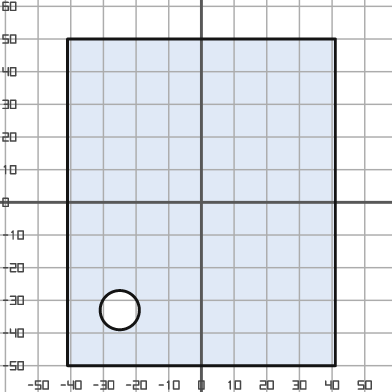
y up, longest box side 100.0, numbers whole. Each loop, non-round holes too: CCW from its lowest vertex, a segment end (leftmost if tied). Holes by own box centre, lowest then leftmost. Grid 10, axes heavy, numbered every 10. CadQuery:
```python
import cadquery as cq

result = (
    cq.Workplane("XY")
    .moveTo(-41.0, -50.0)
    .lineTo(41.0, -50.0)
    .lineTo(41.0, 50.0)
    .lineTo(-41.0, 50.0)
    .close()
    .moveTo(-25.0, -33.0)
    .circle(6.0)
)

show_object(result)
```